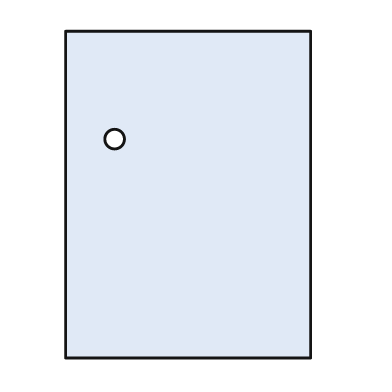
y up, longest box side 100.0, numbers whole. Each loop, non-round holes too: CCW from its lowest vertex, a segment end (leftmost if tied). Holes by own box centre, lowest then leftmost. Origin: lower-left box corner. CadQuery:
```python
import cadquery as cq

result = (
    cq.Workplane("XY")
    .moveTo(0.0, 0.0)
    .lineTo(75.0, 0.0)
    .lineTo(75.0, 100.0)
    .lineTo(0.0, 100.0)
    .close()
    .moveTo(15.0, 67.0)
    .circle(3.0)
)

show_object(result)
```